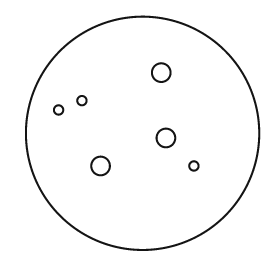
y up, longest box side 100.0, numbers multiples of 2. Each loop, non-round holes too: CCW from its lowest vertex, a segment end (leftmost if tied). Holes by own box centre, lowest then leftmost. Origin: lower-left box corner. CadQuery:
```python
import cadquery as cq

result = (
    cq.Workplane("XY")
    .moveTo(50.0, 50.0)
    .circle(50.0)
    .moveTo(32.0, 36.0)
    .circle(4.0)
    .moveTo(72.0, 36.0)
    .circle(2.0)
    .moveTo(60.0, 48.0)
    .circle(4.0)
    .moveTo(14.0, 60.0)
    .circle(2.0)
    .moveTo(24.0, 64.0)
    .circle(2.0)
    .moveTo(58.0, 76.0)
    .circle(4.0)
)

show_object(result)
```